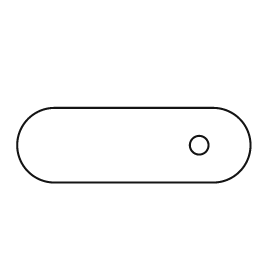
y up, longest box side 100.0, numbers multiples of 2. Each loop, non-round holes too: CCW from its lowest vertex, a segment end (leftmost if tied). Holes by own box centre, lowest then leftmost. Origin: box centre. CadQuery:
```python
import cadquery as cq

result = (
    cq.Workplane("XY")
    .moveTo(-34.0, -16.0)
    .lineTo(34.0, -16.0)
    .threePointArc((50.0, 0.0), (34.0, 16.0))
    .lineTo(-34.0, 16.0)
    .threePointArc((-50.0, 0.0), (-34.0, -16.0))
    .close()
    .moveTo(28.0, 0.0)
    .circle(4.0)
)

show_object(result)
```